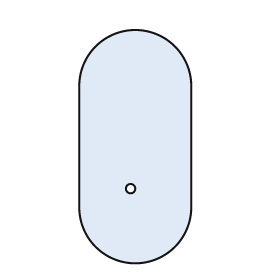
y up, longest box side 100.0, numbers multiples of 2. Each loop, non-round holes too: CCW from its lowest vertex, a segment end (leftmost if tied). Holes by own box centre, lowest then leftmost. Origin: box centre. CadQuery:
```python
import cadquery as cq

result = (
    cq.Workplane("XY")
    .moveTo(-24.0, -26.0)
    .threePointArc((0.0, -50.0), (24.0, -26.0))
    .lineTo(24.0, 26.0)
    .threePointArc((0.0, 50.0), (-24.0, 26.0))
    .close()
    .moveTo(-2.0, -18.0)
    .circle(2.0)
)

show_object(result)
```